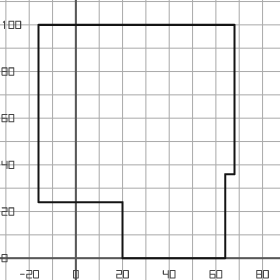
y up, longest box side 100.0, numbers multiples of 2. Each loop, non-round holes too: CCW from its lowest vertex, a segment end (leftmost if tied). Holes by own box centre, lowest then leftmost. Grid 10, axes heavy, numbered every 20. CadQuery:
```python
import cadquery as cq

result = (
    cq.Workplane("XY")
    .moveTo(20.0, 0.0)
    .lineTo(64.0, 0.0)
    .lineTo(64.0, 36.0)
    .lineTo(68.0, 36.0)
    .lineTo(68.0, 100.0)
    .lineTo(-16.0, 100.0)
    .lineTo(-16.0, 24.0)
    .lineTo(20.0, 24.0)
    .close()
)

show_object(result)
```